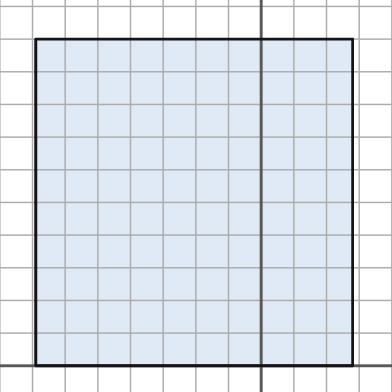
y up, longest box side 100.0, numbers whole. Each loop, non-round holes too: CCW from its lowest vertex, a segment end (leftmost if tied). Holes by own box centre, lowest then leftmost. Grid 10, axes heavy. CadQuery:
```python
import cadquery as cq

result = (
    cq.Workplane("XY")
    .moveTo(-69.0, 0.0)
    .lineTo(28.0, 0.0)
    .lineTo(28.0, 100.0)
    .lineTo(-69.0, 100.0)
    .close()
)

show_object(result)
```